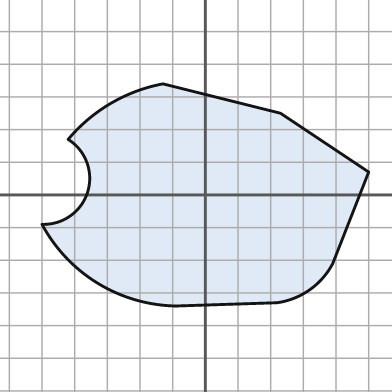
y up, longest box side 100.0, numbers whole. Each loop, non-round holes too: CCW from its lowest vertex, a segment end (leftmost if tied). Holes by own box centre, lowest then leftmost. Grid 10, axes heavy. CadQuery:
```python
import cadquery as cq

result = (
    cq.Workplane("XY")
    .moveTo(-9.0, -34.0)
    .lineTo(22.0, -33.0)
    .threePointArc((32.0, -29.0), (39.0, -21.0))
    .lineTo(50.0, 7.0)
    .lineTo(23.0, 25.0)
    .lineTo(-13.0, 34.0)
    .threePointArc((-29.0, 28.0), (-42.0, 17.0))
    .threePointArc((-36.0, 1.0), (-50.0, -9.0))
    .threePointArc((-33.0, -27.0), (-9.0, -34.0))
    .close()
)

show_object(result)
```